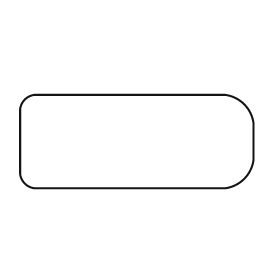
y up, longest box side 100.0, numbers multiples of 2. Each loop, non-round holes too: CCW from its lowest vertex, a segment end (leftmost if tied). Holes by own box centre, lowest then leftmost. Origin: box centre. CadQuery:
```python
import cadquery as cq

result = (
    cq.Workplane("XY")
    .moveTo(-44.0, -20.0)
    .lineTo(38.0, -20.0)
    .threePointArc((46.0, -16.0), (50.0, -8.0))
    .lineTo(50.0, 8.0)
    .threePointArc((46.0, 16.0), (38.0, 20.0))
    .lineTo(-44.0, 20.0)
    .threePointArc((-48.0, 18.0), (-50.0, 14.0))
    .lineTo(-50.0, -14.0)
    .threePointArc((-48.0, -18.0), (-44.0, -20.0))
    .close()
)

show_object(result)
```